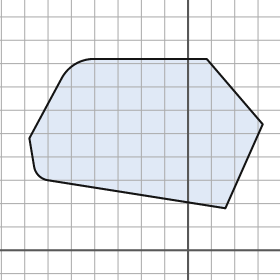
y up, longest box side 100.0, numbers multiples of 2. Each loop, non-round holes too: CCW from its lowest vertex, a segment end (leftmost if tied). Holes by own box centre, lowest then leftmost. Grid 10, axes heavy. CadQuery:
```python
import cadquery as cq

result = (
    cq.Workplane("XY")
    .moveTo(16.0, 18.0)
    .lineTo(32.0, 54.0)
    .lineTo(8.0, 82.0)
    .lineTo(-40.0, 82.0)
    .threePointArc((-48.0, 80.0), (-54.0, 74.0))
    .lineTo(-68.0, 48.0)
    .lineTo(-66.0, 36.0)
    .threePointArc((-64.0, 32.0), (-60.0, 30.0))
    .close()
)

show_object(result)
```